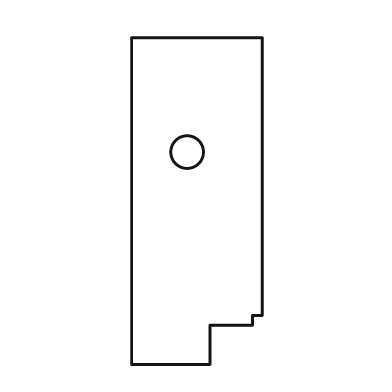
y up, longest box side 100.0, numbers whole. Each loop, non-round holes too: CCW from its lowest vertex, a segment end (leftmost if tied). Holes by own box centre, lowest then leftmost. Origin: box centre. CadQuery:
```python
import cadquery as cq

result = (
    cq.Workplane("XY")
    .moveTo(-20.0, -50.0)
    .lineTo(4.0, -50.0)
    .lineTo(4.0, -38.0)
    .lineTo(17.0, -38.0)
    .lineTo(17.0, -35.0)
    .lineTo(20.0, -35.0)
    .lineTo(20.0, 50.0)
    .lineTo(-20.0, 50.0)
    .close()
    .moveTo(-3.0, 15.0)
    .circle(5.0)
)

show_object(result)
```